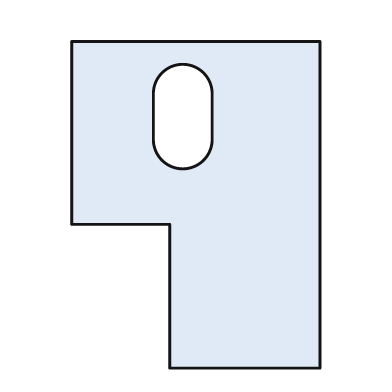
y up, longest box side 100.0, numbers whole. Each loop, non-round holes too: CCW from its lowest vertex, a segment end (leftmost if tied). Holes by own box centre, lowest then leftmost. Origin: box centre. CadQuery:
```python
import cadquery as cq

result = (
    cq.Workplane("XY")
    .moveTo(-8.0, -50.0)
    .lineTo(38.0, -50.0)
    .lineTo(38.0, 50.0)
    .lineTo(-38.0, 50.0)
    .lineTo(-38.0, -6.0)
    .lineTo(-8.0, -6.0)
    .close()
    .moveTo(-13.0, 20.0)
    .threePointArc((-4.0, 11.0), (5.0, 20.0))
    .lineTo(5.0, 34.0)
    .threePointArc((-4.0, 43.0), (-13.0, 34.0))
    .close()
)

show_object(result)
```